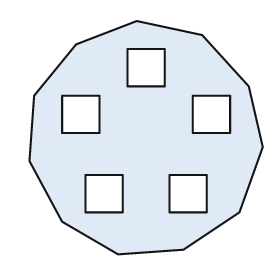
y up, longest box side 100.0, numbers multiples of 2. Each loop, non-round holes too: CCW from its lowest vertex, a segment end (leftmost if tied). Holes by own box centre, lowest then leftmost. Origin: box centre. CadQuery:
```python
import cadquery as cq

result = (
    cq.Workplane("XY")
    .moveTo(-12.0, -50.0)
    .lineTo(16.0, -48.0)
    .lineTo(40.0, -32.0)
    .lineTo(50.0, -4.0)
    .lineTo(44.0, 22.0)
    .lineTo(24.0, 44.0)
    .lineTo(-4.0, 50.0)
    .lineTo(-30.0, 40.0)
    .lineTo(-48.0, 18.0)
    .lineTo(-50.0, -10.0)
    .lineTo(-36.0, -36.0)
    .close()
    .moveTo(-26.0, -32.0)
    .lineTo(-10.0, -32.0)
    .lineTo(-10.0, -16.0)
    .lineTo(-26.0, -16.0)
    .close()
    .moveTo(10.0, -32.0)
    .lineTo(26.0, -32.0)
    .lineTo(26.0, -16.0)
    .lineTo(10.0, -16.0)
    .close()
    .moveTo(-36.0, 2.0)
    .lineTo(-20.0, 2.0)
    .lineTo(-20.0, 18.0)
    .lineTo(-36.0, 18.0)
    .close()
    .moveTo(20.0, 2.0)
    .lineTo(36.0, 2.0)
    .lineTo(36.0, 18.0)
    .lineTo(20.0, 18.0)
    .close()
    .moveTo(-8.0, 22.0)
    .lineTo(8.0, 22.0)
    .lineTo(8.0, 38.0)
    .lineTo(-8.0, 38.0)
    .close()
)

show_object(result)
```